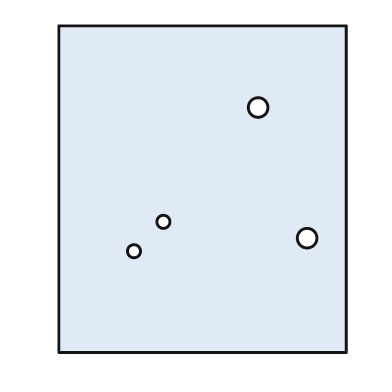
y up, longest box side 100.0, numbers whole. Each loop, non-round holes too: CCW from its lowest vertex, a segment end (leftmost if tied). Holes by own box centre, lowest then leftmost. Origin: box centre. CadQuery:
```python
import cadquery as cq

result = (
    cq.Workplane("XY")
    .moveTo(-44.0, -50.0)
    .lineTo(44.0, -50.0)
    .lineTo(44.0, 50.0)
    .lineTo(-44.0, 50.0)
    .close()
    .moveTo(-21.0, -19.0)
    .circle(2.0)
    .moveTo(32.0, -15.0)
    .circle(3.0)
    .moveTo(-12.0, -10.0)
    .circle(2.0)
    .moveTo(17.0, 25.0)
    .circle(3.0)
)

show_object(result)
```